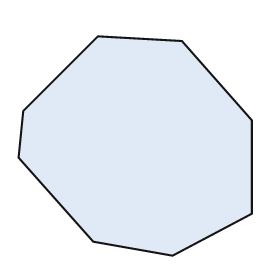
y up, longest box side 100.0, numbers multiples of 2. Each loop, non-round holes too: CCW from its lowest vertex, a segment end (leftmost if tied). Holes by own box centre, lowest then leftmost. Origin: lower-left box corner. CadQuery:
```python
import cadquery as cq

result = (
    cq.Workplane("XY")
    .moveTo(66.0, 0.0)
    .lineTo(100.0, 18.0)
    .lineTo(100.0, 58.0)
    .lineTo(70.0, 92.0)
    .lineTo(34.0, 94.0)
    .lineTo(2.0, 62.0)
    .lineTo(0.0, 42.0)
    .lineTo(32.0, 6.0)
    .close()
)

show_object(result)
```